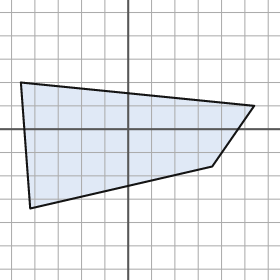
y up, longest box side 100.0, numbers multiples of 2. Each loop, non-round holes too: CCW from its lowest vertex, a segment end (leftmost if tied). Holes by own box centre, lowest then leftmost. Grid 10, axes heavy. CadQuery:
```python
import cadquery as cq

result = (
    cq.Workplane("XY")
    .moveTo(-42.0, -34.0)
    .lineTo(36.0, -16.0)
    .lineTo(54.0, 10.0)
    .lineTo(-46.0, 20.0)
    .close()
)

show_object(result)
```